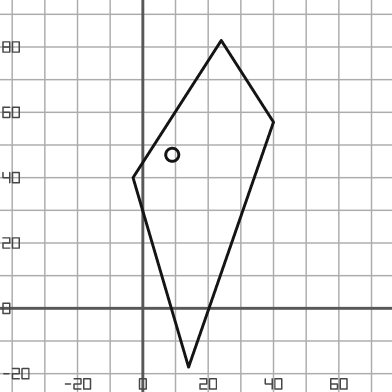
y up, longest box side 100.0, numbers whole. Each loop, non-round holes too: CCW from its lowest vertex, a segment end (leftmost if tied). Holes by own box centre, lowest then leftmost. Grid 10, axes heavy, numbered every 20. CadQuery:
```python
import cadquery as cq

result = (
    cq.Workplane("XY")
    .moveTo(14.0, -18.0)
    .lineTo(40.0, 57.0)
    .lineTo(24.0, 82.0)
    .lineTo(-3.0, 40.0)
    .close()
    .moveTo(9.0, 47.0)
    .circle(2.0)
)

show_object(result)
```